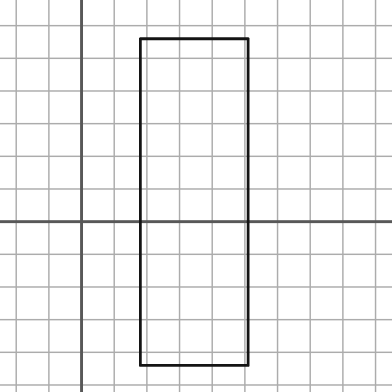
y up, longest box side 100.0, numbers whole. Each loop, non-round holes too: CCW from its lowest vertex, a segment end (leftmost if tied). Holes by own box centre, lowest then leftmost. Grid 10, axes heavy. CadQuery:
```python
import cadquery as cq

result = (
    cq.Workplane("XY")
    .moveTo(18.0, -44.0)
    .lineTo(51.0, -44.0)
    .lineTo(51.0, 56.0)
    .lineTo(18.0, 56.0)
    .close()
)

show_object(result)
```